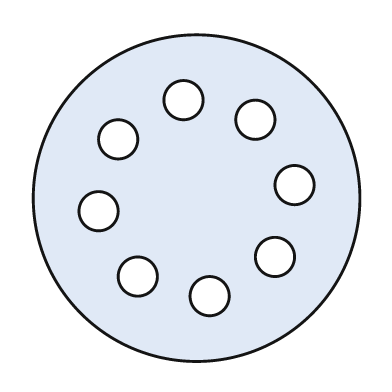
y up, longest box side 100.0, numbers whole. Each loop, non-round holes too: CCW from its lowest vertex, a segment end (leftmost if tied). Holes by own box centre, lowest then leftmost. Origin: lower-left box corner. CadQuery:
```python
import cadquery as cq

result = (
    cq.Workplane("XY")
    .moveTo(50.0, 50.0)
    .circle(50.0)
    .moveTo(54.0, 20.0)
    .circle(6.0)
    .moveTo(32.0, 26.0)
    .circle(6.0)
    .moveTo(74.0, 32.0)
    .circle(6.0)
    .moveTo(20.0, 46.0)
    .circle(6.0)
    .moveTo(80.0, 54.0)
    .circle(6.0)
    .moveTo(26.0, 68.0)
    .circle(6.0)
    .moveTo(68.0, 74.0)
    .circle(6.0)
    .moveTo(46.0, 80.0)
    .circle(6.0)
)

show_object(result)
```